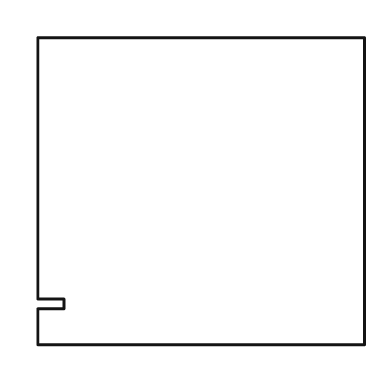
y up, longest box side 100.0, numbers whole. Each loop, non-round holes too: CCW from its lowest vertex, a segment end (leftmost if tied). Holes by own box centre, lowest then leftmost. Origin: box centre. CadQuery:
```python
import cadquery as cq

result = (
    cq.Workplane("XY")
    .moveTo(-50.0, -47.0)
    .lineTo(50.0, -47.0)
    .lineTo(50.0, 47.0)
    .lineTo(-50.0, 47.0)
    .lineTo(-50.0, -33.0)
    .lineTo(-42.0, -33.0)
    .lineTo(-42.0, -36.0)
    .lineTo(-50.0, -36.0)
    .close()
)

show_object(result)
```